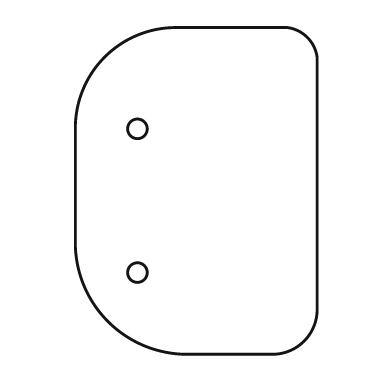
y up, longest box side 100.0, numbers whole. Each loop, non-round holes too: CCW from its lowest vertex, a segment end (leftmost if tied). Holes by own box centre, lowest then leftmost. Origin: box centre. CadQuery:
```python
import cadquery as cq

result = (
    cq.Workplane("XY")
    .moveTo(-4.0, -50.0)
    .lineTo(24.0, -50.0)
    .threePointArc((33.0, -46.0), (37.0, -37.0))
    .lineTo(37.0, 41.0)
    .threePointArc((34.0, 47.0), (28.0, 50.0))
    .lineTo(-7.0, 50.0)
    .threePointArc((-28.0, 41.0), (-37.0, 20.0))
    .lineTo(-37.0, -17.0)
    .threePointArc((-27.0, -40.0), (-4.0, -50.0))
    .close()
    .moveTo(-18.0, -25.0)
    .circle(3.0)
    .moveTo(-18.0, 19.0)
    .circle(3.0)
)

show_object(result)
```